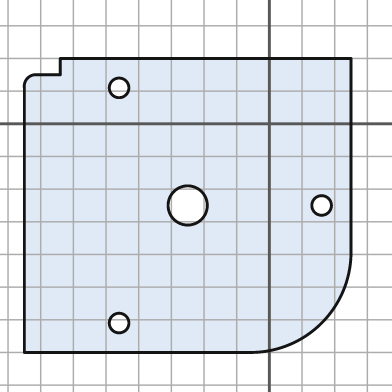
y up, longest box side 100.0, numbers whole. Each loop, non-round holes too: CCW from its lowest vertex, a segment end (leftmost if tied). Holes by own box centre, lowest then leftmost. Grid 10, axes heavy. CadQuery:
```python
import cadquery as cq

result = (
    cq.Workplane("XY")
    .moveTo(-75.0, -70.0)
    .lineTo(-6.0, -70.0)
    .threePointArc((16.0, -61.0), (25.0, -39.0))
    .lineTo(25.0, 20.0)
    .lineTo(-64.0, 20.0)
    .lineTo(-64.0, 15.0)
    .lineTo(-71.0, 15.0)
    .threePointArc((-74.0, 14.0), (-75.0, 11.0))
    .close()
    .moveTo(-46.0, -61.0)
    .circle(3.0)
    .moveTo(-25.0, -25.0)
    .circle(6.0)
    .moveTo(16.0, -25.0)
    .circle(3.0)
    .moveTo(-46.0, 11.0)
    .circle(3.0)
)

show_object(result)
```